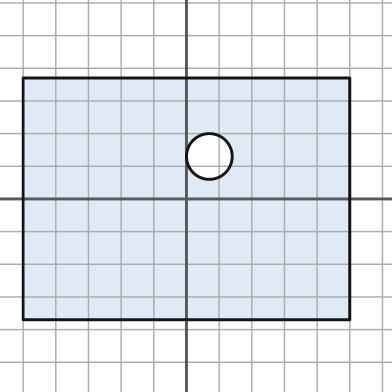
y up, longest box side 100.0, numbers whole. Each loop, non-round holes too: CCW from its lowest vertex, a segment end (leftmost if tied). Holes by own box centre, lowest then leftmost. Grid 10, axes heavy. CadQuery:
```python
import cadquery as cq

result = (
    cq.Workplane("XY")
    .moveTo(-50.0, -37.0)
    .lineTo(50.0, -37.0)
    .lineTo(50.0, 37.0)
    .lineTo(-50.0, 37.0)
    .close()
    .moveTo(7.0, 13.0)
    .circle(7.0)
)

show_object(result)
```